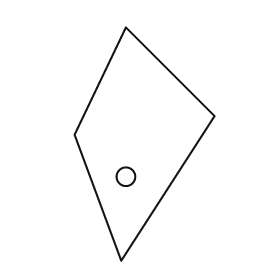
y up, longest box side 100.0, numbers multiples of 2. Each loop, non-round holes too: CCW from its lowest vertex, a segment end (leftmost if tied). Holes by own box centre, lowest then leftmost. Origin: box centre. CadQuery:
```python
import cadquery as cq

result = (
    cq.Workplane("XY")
    .moveTo(-10.0, -50.0)
    .lineTo(30.0, 12.0)
    .lineTo(-8.0, 50.0)
    .lineTo(-30.0, 4.0)
    .close()
    .moveTo(-8.0, -14.0)
    .circle(4.0)
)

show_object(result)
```